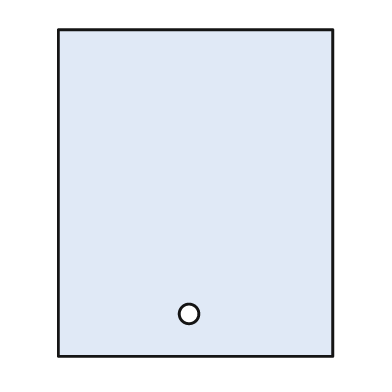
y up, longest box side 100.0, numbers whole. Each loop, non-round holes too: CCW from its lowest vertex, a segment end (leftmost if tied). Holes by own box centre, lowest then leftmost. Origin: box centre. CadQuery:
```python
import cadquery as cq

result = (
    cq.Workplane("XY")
    .moveTo(-42.0, -50.0)
    .lineTo(42.0, -50.0)
    .lineTo(42.0, 50.0)
    .lineTo(-42.0, 50.0)
    .close()
    .moveTo(-2.0, -37.0)
    .circle(3.0)
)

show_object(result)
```